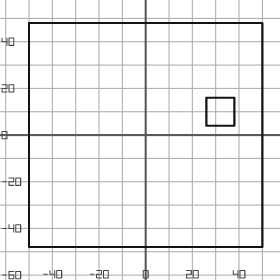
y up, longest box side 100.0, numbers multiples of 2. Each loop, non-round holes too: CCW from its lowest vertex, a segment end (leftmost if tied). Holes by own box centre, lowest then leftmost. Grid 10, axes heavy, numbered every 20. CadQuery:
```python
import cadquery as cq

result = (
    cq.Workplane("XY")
    .moveTo(-50.0, -48.0)
    .lineTo(50.0, -48.0)
    .lineTo(50.0, 48.0)
    .lineTo(-50.0, 48.0)
    .close()
    .moveTo(26.0, 4.0)
    .lineTo(38.0, 4.0)
    .lineTo(38.0, 16.0)
    .lineTo(26.0, 16.0)
    .close()
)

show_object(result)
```